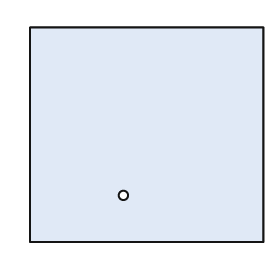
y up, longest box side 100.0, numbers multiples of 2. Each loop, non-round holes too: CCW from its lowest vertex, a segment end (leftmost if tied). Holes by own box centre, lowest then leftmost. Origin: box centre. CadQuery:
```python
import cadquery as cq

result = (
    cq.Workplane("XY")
    .moveTo(-50.0, -46.0)
    .lineTo(50.0, -46.0)
    .lineTo(50.0, 46.0)
    .lineTo(-50.0, 46.0)
    .close()
    .moveTo(-10.0, -26.0)
    .circle(2.0)
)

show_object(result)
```